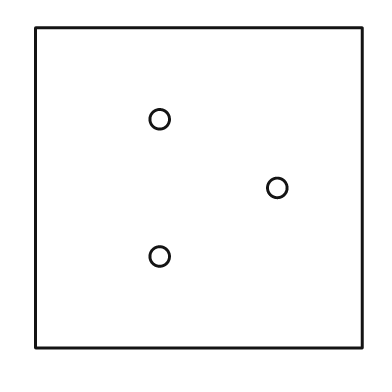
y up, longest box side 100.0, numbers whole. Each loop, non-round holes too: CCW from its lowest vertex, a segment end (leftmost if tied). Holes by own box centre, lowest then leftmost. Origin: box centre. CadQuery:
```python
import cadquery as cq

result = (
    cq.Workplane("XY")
    .moveTo(-50.0, -49.0)
    .lineTo(50.0, -49.0)
    .lineTo(50.0, 49.0)
    .lineTo(-50.0, 49.0)
    .close()
    .moveTo(-12.0, -21.0)
    .circle(3.0)
    .moveTo(24.0, 0.0)
    .circle(3.0)
    .moveTo(-12.0, 21.0)
    .circle(3.0)
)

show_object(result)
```